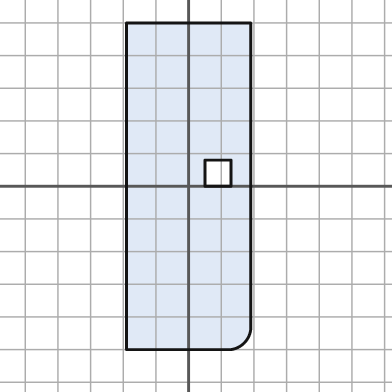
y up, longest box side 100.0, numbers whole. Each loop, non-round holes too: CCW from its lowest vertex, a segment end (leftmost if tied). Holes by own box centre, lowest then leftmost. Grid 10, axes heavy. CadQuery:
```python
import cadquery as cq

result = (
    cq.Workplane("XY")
    .moveTo(-19.0, -50.0)
    .lineTo(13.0, -50.0)
    .threePointArc((17.0, -48.0), (19.0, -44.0))
    .lineTo(19.0, 50.0)
    .lineTo(-19.0, 50.0)
    .close()
    .moveTo(5.0, 0.0)
    .lineTo(13.0, 0.0)
    .lineTo(13.0, 8.0)
    .lineTo(5.0, 8.0)
    .close()
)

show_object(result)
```